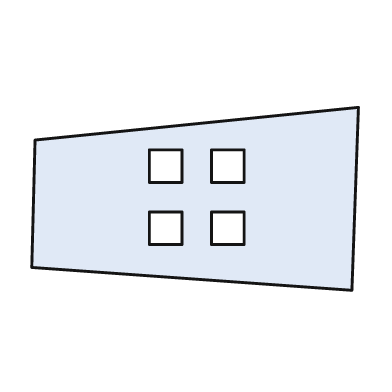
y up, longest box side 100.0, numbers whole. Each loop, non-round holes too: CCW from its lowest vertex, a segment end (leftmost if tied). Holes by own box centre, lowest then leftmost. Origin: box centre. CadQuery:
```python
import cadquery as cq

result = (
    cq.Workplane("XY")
    .moveTo(48.0, -28.0)
    .lineTo(50.0, 28.0)
    .lineTo(-49.0, 18.0)
    .lineTo(-50.0, -21.0)
    .close()
    .moveTo(-14.0, -14.0)
    .lineTo(-4.0, -14.0)
    .lineTo(-4.0, -4.0)
    .lineTo(-14.0, -4.0)
    .close()
    .moveTo(5.0, -14.0)
    .lineTo(15.0, -14.0)
    .lineTo(15.0, -4.0)
    .lineTo(5.0, -4.0)
    .close()
    .moveTo(-14.0, 5.0)
    .lineTo(-4.0, 5.0)
    .lineTo(-4.0, 15.0)
    .lineTo(-14.0, 15.0)
    .close()
    .moveTo(5.0, 5.0)
    .lineTo(15.0, 5.0)
    .lineTo(15.0, 15.0)
    .lineTo(5.0, 15.0)
    .close()
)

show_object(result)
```